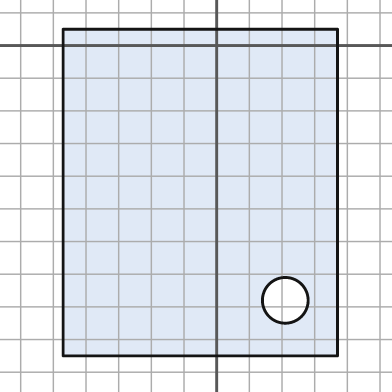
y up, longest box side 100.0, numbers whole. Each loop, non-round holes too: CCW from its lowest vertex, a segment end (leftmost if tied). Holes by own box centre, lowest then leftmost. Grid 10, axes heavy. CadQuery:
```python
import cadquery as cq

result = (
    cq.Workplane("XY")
    .moveTo(-47.0, -95.0)
    .lineTo(37.0, -95.0)
    .lineTo(37.0, 5.0)
    .lineTo(-47.0, 5.0)
    .close()
    .moveTo(21.0, -78.0)
    .circle(7.0)
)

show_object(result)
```